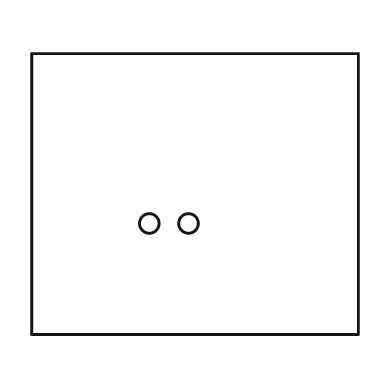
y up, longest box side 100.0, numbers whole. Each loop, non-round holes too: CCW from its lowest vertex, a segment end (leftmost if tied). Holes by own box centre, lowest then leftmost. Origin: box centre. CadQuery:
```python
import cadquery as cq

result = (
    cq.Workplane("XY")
    .moveTo(-50.0, -43.0)
    .lineTo(50.0, -43.0)
    .lineTo(50.0, 43.0)
    .lineTo(-50.0, 43.0)
    .close()
    .moveTo(-14.0, -9.0)
    .circle(3.0)
    .moveTo(-2.0, -9.0)
    .circle(3.0)
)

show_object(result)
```